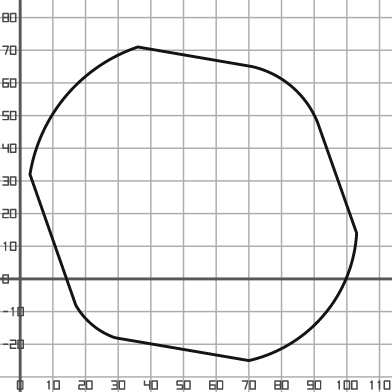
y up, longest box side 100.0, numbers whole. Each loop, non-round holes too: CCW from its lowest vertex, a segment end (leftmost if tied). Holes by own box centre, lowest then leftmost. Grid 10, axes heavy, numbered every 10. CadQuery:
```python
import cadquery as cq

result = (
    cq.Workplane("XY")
    .moveTo(70.0, -25.0)
    .threePointArc((93.0, -11.0), (103.0, 14.0))
    .lineTo(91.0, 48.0)
    .threePointArc((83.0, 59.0), (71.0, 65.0))
    .lineTo(36.0, 71.0)
    .threePointArc((14.0, 56.0), (3.0, 32.0))
    .lineTo(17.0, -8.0)
    .threePointArc((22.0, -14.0), (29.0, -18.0))
    .close()
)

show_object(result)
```